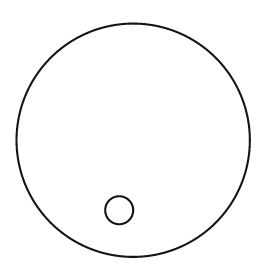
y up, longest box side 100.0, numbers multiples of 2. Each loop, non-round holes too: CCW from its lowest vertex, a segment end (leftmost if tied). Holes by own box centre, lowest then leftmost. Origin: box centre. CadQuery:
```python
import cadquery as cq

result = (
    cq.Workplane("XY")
    .moveTo(0.0, 0.0)
    .circle(50.0)
    .moveTo(-6.0, -30.0)
    .circle(6.0)
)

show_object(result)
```